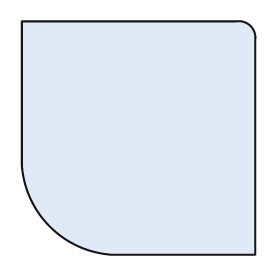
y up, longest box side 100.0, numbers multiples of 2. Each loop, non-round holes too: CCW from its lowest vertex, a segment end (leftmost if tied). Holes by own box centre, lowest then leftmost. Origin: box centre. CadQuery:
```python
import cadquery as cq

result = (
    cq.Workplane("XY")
    .moveTo(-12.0, -50.0)
    .lineTo(50.0, -50.0)
    .lineTo(50.0, 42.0)
    .threePointArc((48.0, 48.0), (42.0, 50.0))
    .lineTo(-50.0, 50.0)
    .lineTo(-50.0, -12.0)
    .threePointArc((-38.0, -38.0), (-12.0, -50.0))
    .close()
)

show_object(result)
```